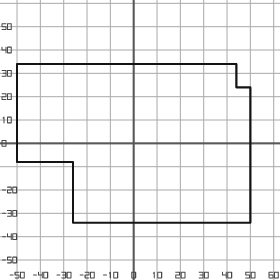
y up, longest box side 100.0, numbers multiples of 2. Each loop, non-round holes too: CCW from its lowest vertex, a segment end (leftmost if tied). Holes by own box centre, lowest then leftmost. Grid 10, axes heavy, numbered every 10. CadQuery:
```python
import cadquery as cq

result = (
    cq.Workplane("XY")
    .moveTo(-26.0, -34.0)
    .lineTo(50.0, -34.0)
    .lineTo(50.0, 24.0)
    .lineTo(44.0, 24.0)
    .lineTo(44.0, 34.0)
    .lineTo(-50.0, 34.0)
    .lineTo(-50.0, -8.0)
    .lineTo(-26.0, -8.0)
    .close()
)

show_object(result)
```